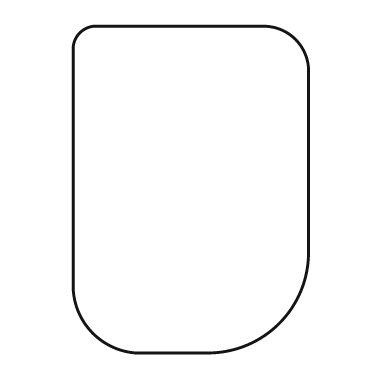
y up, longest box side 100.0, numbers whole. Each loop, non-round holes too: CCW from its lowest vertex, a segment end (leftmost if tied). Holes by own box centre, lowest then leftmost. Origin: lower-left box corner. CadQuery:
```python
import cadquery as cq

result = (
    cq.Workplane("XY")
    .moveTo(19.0, 0.0)
    .lineTo(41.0, 0.0)
    .threePointArc((63.0, 9.0), (72.0, 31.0))
    .lineTo(72.0, 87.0)
    .threePointArc((68.0, 96.0), (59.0, 100.0))
    .lineTo(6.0, 100.0)
    .threePointArc((2.0, 98.0), (0.0, 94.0))
    .lineTo(0.0, 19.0)
    .threePointArc((6.0, 6.0), (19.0, 0.0))
    .close()
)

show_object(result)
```